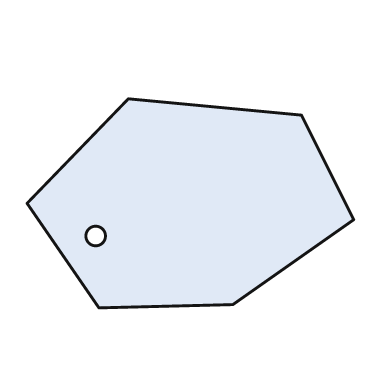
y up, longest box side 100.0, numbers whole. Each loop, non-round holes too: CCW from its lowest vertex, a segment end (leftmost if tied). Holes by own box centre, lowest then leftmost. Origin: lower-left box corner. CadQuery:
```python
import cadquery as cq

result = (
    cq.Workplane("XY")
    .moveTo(22.0, 0.0)
    .lineTo(63.0, 1.0)
    .lineTo(100.0, 27.0)
    .lineTo(84.0, 59.0)
    .lineTo(31.0, 64.0)
    .lineTo(0.0, 32.0)
    .close()
    .moveTo(21.0, 22.0)
    .circle(3.0)
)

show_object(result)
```